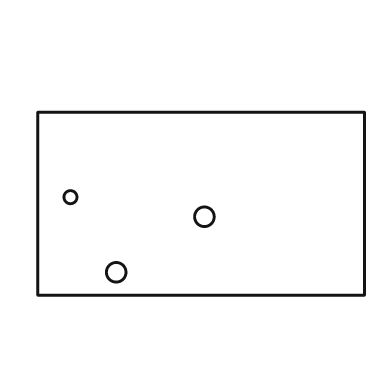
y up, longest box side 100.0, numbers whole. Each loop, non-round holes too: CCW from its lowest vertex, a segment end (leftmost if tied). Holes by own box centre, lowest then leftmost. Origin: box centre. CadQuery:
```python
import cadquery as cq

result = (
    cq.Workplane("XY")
    .moveTo(-50.0, -28.0)
    .lineTo(50.0, -28.0)
    .lineTo(50.0, 28.0)
    .lineTo(-50.0, 28.0)
    .close()
    .moveTo(-26.0, -21.0)
    .circle(3.0)
    .moveTo(1.0, -4.0)
    .circle(3.0)
    .moveTo(-40.0, 2.0)
    .circle(2.0)
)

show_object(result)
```